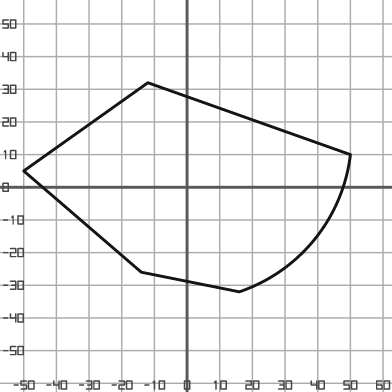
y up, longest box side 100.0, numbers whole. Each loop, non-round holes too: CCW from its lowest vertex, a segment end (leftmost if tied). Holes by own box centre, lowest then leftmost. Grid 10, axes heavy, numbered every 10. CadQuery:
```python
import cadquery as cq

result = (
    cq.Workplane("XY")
    .moveTo(16.0, -32.0)
    .threePointArc((39.0, -16.0), (50.0, 10.0))
    .lineTo(-12.0, 32.0)
    .lineTo(-50.0, 5.0)
    .lineTo(-14.0, -26.0)
    .close()
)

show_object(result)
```